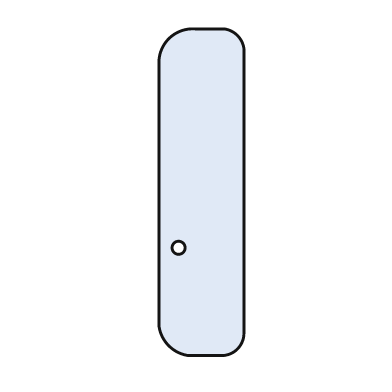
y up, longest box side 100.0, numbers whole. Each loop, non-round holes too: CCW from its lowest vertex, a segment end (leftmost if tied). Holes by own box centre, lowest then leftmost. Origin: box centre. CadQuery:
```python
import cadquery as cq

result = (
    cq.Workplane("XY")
    .moveTo(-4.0, -50.0)
    .lineTo(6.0, -50.0)
    .threePointArc((11.0, -48.0), (13.0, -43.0))
    .lineTo(13.0, 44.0)
    .threePointArc((11.0, 48.0), (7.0, 50.0))
    .lineTo(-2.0, 50.0)
    .threePointArc((-10.0, 47.0), (-13.0, 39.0))
    .lineTo(-13.0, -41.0)
    .threePointArc((-10.0, -47.0), (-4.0, -50.0))
    .close()
    .moveTo(-7.0, -17.0)
    .circle(2.0)
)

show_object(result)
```